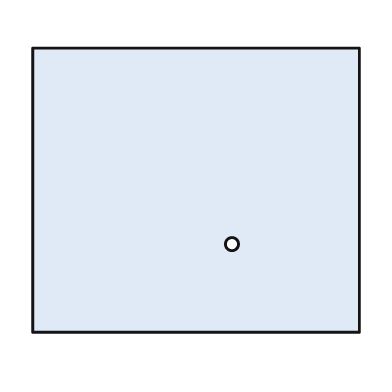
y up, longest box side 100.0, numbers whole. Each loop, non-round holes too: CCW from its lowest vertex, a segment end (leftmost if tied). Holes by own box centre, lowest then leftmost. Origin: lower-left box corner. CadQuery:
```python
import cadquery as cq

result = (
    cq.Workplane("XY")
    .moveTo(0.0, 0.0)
    .lineTo(100.0, 0.0)
    .lineTo(100.0, 87.0)
    .lineTo(0.0, 87.0)
    .close()
    .moveTo(61.0, 27.0)
    .circle(2.0)
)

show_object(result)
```